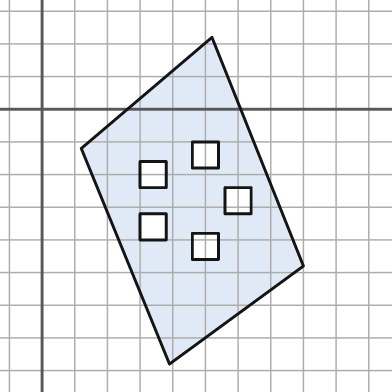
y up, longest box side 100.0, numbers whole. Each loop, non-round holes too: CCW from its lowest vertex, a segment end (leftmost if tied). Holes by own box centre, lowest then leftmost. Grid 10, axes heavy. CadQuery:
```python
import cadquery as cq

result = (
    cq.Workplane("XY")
    .moveTo(39.0, -78.0)
    .lineTo(80.0, -48.0)
    .lineTo(52.0, 22.0)
    .lineTo(12.0, -12.0)
    .close()
    .moveTo(46.0, -46.0)
    .lineTo(54.0, -46.0)
    .lineTo(54.0, -38.0)
    .lineTo(46.0, -38.0)
    .close()
    .moveTo(30.0, -40.0)
    .lineTo(38.0, -40.0)
    .lineTo(38.0, -32.0)
    .lineTo(30.0, -32.0)
    .close()
    .moveTo(56.0, -32.0)
    .lineTo(64.0, -32.0)
    .lineTo(64.0, -24.0)
    .lineTo(56.0, -24.0)
    .close()
    .moveTo(30.0, -24.0)
    .lineTo(38.0, -24.0)
    .lineTo(38.0, -16.0)
    .lineTo(30.0, -16.0)
    .close()
    .moveTo(46.0, -18.0)
    .lineTo(54.0, -18.0)
    .lineTo(54.0, -10.0)
    .lineTo(46.0, -10.0)
    .close()
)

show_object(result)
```